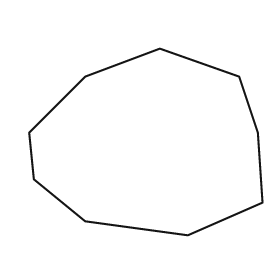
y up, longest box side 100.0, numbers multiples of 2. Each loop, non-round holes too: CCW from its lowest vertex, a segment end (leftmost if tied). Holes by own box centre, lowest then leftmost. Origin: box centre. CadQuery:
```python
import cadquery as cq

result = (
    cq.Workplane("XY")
    .moveTo(18.0, -40.0)
    .lineTo(50.0, -26.0)
    .lineTo(48.0, 4.0)
    .lineTo(40.0, 28.0)
    .lineTo(6.0, 40.0)
    .lineTo(-26.0, 28.0)
    .lineTo(-50.0, 4.0)
    .lineTo(-48.0, -16.0)
    .lineTo(-26.0, -34.0)
    .close()
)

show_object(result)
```